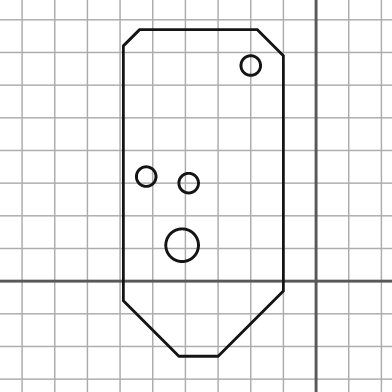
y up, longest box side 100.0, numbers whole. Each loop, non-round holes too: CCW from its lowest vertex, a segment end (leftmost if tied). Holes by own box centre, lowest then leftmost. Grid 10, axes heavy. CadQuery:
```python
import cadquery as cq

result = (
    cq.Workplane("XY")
    .moveTo(-42.0, -23.0)
    .lineTo(-30.0, -23.0)
    .lineTo(-10.0, -3.0)
    .lineTo(-10.0, 69.0)
    .lineTo(-18.0, 77.0)
    .lineTo(-54.0, 77.0)
    .lineTo(-59.0, 72.0)
    .lineTo(-59.0, -6.0)
    .close()
    .moveTo(-41.0, 11.0)
    .circle(5.0)
    .moveTo(-39.0, 30.0)
    .circle(3.0)
    .moveTo(-52.0, 32.0)
    .circle(3.0)
    .moveTo(-20.0, 66.0)
    .circle(3.0)
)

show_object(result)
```